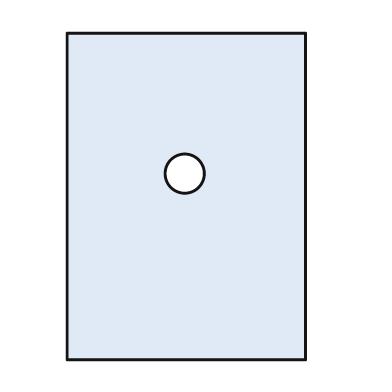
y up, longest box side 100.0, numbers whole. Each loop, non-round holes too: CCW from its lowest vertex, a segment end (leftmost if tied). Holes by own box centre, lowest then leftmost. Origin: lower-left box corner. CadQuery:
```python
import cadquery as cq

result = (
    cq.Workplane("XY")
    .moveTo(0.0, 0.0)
    .lineTo(73.0, 0.0)
    .lineTo(73.0, 100.0)
    .lineTo(0.0, 100.0)
    .close()
    .moveTo(36.0, 57.0)
    .circle(6.0)
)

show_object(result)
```